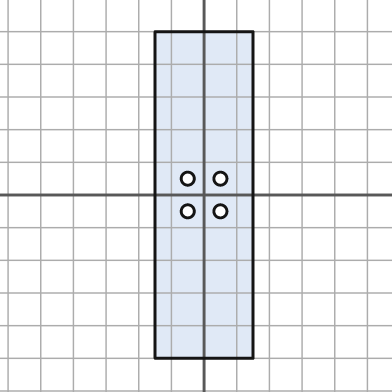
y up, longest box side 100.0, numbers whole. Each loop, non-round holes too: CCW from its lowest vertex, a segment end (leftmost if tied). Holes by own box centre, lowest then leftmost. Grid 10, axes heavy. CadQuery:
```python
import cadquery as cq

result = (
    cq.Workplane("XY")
    .moveTo(-15.0, -50.0)
    .lineTo(15.0, -50.0)
    .lineTo(15.0, 50.0)
    .lineTo(-15.0, 50.0)
    .close()
    .moveTo(-5.0, -5.0)
    .circle(2.0)
    .moveTo(5.0, -5.0)
    .circle(2.0)
    .moveTo(-5.0, 5.0)
    .circle(2.0)
    .moveTo(5.0, 5.0)
    .circle(2.0)
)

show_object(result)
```